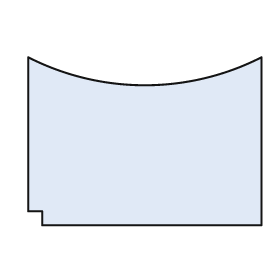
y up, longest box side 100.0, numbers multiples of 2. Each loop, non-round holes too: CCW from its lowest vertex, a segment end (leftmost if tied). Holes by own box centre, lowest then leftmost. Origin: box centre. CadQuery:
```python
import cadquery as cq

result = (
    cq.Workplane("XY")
    .moveTo(-44.0, -36.0)
    .lineTo(50.0, -36.0)
    .lineTo(50.0, 36.0)
    .threePointArc((0.0, 24.0), (-50.0, 36.0))
    .lineTo(-50.0, -30.0)
    .lineTo(-44.0, -30.0)
    .close()
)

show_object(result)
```